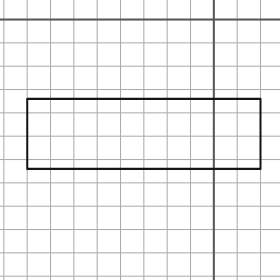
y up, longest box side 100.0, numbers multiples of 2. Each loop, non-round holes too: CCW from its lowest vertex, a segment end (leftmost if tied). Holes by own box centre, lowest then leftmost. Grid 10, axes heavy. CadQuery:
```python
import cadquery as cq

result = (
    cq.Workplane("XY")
    .moveTo(-80.0, -64.0)
    .lineTo(20.0, -64.0)
    .lineTo(20.0, -34.0)
    .lineTo(-80.0, -34.0)
    .close()
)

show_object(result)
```